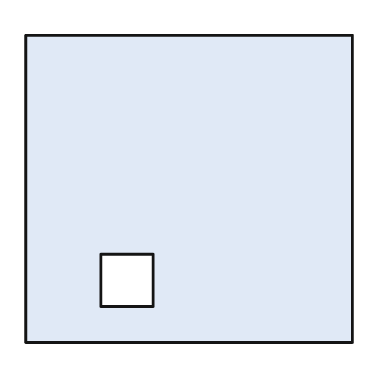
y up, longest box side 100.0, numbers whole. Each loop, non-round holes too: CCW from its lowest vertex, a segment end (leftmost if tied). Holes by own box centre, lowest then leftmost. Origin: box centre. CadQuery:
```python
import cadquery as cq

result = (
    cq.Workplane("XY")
    .moveTo(-50.0, -47.0)
    .lineTo(50.0, -47.0)
    .lineTo(50.0, 47.0)
    .lineTo(-50.0, 47.0)
    .close()
    .moveTo(-27.0, -36.0)
    .lineTo(-11.0, -36.0)
    .lineTo(-11.0, -20.0)
    .lineTo(-27.0, -20.0)
    .close()
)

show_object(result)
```